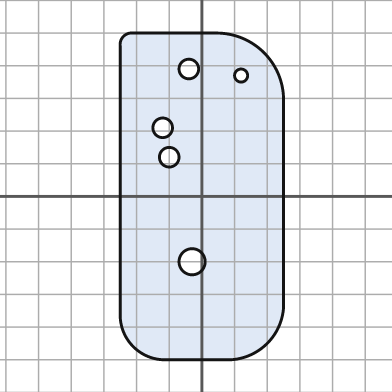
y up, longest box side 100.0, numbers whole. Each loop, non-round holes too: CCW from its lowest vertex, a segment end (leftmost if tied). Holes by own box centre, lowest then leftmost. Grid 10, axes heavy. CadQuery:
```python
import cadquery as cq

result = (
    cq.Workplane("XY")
    .moveTo(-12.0, -50.0)
    .lineTo(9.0, -50.0)
    .threePointArc((20.0, -45.0), (25.0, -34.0))
    .lineTo(25.0, 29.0)
    .threePointArc((19.0, 44.0), (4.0, 50.0))
    .lineTo(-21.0, 50.0)
    .threePointArc((-24.0, 49.0), (-25.0, 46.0))
    .lineTo(-25.0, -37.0)
    .threePointArc((-21.0, -46.0), (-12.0, -50.0))
    .close()
    .moveTo(-3.0, -20.0)
    .circle(4.0)
    .moveTo(-10.0, 12.0)
    .circle(3.0)
    .moveTo(-12.0, 21.0)
    .circle(3.0)
    .moveTo(12.0, 37.0)
    .circle(2.0)
    .moveTo(-4.0, 39.0)
    .circle(3.0)
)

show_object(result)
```